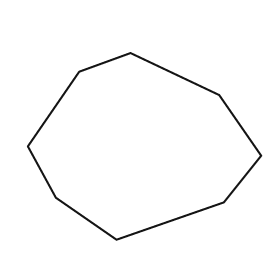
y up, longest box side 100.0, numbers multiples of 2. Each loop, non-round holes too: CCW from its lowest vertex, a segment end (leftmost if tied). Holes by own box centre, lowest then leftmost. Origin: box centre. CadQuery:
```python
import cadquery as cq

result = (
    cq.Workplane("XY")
    .moveTo(-12.0, -40.0)
    .lineTo(34.0, -24.0)
    .lineTo(50.0, -4.0)
    .lineTo(32.0, 22.0)
    .lineTo(-6.0, 40.0)
    .lineTo(-28.0, 32.0)
    .lineTo(-50.0, 0.0)
    .lineTo(-38.0, -22.0)
    .close()
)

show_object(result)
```